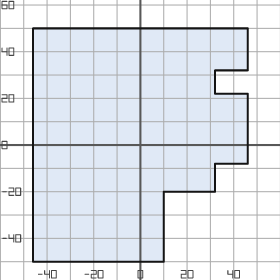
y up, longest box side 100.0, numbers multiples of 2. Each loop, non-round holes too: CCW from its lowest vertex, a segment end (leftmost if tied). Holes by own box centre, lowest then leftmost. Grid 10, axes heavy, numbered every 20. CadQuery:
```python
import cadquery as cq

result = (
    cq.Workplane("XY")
    .moveTo(-46.0, -50.0)
    .lineTo(10.0, -50.0)
    .lineTo(10.0, -20.0)
    .lineTo(32.0, -20.0)
    .lineTo(32.0, -8.0)
    .lineTo(46.0, -8.0)
    .lineTo(46.0, 22.0)
    .lineTo(32.0, 22.0)
    .lineTo(32.0, 32.0)
    .lineTo(46.0, 32.0)
    .lineTo(46.0, 50.0)
    .lineTo(-46.0, 50.0)
    .close()
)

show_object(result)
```